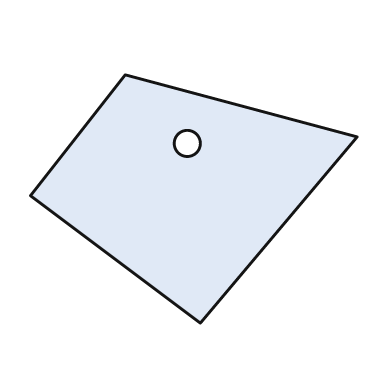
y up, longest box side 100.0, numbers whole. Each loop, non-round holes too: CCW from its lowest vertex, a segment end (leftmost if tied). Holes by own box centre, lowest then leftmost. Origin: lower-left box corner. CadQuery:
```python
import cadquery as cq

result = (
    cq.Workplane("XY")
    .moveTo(52.0, 0.0)
    .lineTo(100.0, 57.0)
    .lineTo(29.0, 76.0)
    .lineTo(0.0, 39.0)
    .close()
    .moveTo(48.0, 55.0)
    .circle(4.0)
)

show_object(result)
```